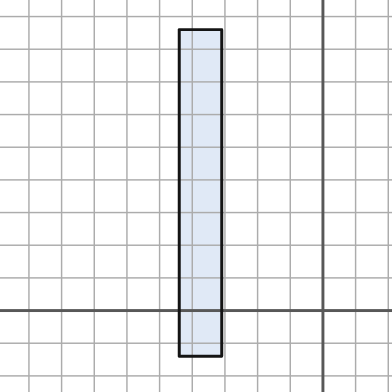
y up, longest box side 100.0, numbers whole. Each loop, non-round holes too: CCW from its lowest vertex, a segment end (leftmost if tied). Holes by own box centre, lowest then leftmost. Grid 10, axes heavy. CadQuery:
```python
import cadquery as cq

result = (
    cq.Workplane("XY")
    .moveTo(-44.0, -14.0)
    .lineTo(-31.0, -14.0)
    .lineTo(-31.0, 86.0)
    .lineTo(-44.0, 86.0)
    .close()
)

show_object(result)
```